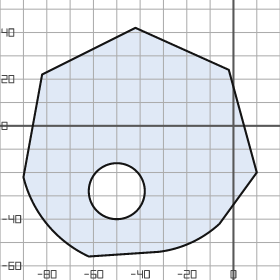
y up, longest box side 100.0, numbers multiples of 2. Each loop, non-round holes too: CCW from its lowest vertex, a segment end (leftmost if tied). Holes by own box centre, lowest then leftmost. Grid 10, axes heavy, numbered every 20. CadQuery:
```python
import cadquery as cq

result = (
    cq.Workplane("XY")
    .moveTo(-62.0, -56.0)
    .lineTo(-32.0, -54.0)
    .threePointArc((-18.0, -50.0), (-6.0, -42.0))
    .lineTo(10.0, -20.0)
    .lineTo(-2.0, 24.0)
    .lineTo(-42.0, 42.0)
    .lineTo(-82.0, 22.0)
    .lineTo(-90.0, -22.0)
    .threePointArc((-80.0, -42.0), (-62.0, -56.0))
    .close()
    .moveTo(-50.0, -28.0)
    .circle(12.0)
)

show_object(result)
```